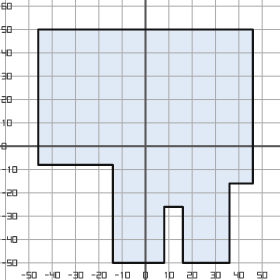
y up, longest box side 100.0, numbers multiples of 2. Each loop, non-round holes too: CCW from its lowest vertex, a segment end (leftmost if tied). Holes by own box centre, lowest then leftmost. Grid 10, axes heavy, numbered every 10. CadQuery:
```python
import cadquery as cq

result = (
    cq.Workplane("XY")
    .moveTo(-14.0, -50.0)
    .lineTo(8.0, -50.0)
    .lineTo(8.0, -26.0)
    .lineTo(16.0, -26.0)
    .lineTo(16.0, -50.0)
    .lineTo(36.0, -50.0)
    .lineTo(36.0, -16.0)
    .lineTo(46.0, -16.0)
    .lineTo(46.0, 50.0)
    .lineTo(-46.0, 50.0)
    .lineTo(-46.0, -8.0)
    .lineTo(-14.0, -8.0)
    .close()
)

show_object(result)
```